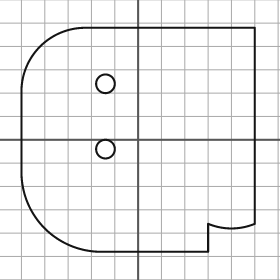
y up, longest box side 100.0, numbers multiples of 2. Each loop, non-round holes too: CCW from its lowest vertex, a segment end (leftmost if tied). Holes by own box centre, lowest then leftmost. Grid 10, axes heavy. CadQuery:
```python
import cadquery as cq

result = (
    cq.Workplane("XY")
    .moveTo(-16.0, -48.0)
    .lineTo(30.0, -48.0)
    .lineTo(30.0, -36.0)
    .threePointArc((40.0, -38.0), (50.0, -36.0))
    .lineTo(50.0, 48.0)
    .lineTo(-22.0, 48.0)
    .threePointArc((-42.0, 40.0), (-50.0, 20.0))
    .lineTo(-50.0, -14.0)
    .threePointArc((-40.0, -38.0), (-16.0, -48.0))
    .close()
    .moveTo(-14.0, -4.0)
    .circle(4.0)
    .moveTo(-14.0, 24.0)
    .circle(4.0)
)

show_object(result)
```